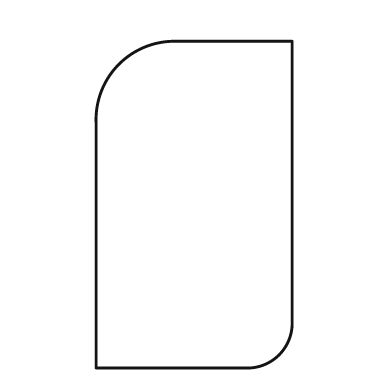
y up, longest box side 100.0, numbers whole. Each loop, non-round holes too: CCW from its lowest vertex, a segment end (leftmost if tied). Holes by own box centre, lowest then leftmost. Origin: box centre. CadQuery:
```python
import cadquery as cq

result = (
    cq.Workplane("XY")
    .moveTo(-30.0, -50.0)
    .lineTo(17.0, -50.0)
    .threePointArc((26.0, -46.0), (30.0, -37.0))
    .lineTo(30.0, 50.0)
    .lineTo(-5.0, 50.0)
    .threePointArc((-23.0, 43.0), (-30.0, 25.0))
    .close()
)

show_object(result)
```